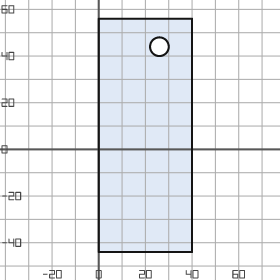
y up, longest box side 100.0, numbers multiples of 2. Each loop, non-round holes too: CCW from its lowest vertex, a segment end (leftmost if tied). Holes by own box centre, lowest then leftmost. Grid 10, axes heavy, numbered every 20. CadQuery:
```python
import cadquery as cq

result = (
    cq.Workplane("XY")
    .moveTo(0.0, -44.0)
    .lineTo(40.0, -44.0)
    .lineTo(40.0, 56.0)
    .lineTo(0.0, 56.0)
    .close()
    .moveTo(26.0, 44.0)
    .circle(4.0)
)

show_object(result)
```